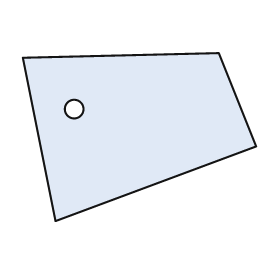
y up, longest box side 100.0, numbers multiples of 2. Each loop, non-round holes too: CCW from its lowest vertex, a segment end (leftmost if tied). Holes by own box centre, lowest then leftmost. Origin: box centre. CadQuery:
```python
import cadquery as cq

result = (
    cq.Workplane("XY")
    .moveTo(-36.0, -36.0)
    .lineTo(50.0, -4.0)
    .lineTo(34.0, 36.0)
    .lineTo(-50.0, 34.0)
    .close()
    .moveTo(-28.0, 12.0)
    .circle(4.0)
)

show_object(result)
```